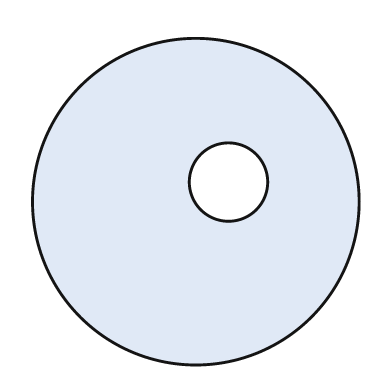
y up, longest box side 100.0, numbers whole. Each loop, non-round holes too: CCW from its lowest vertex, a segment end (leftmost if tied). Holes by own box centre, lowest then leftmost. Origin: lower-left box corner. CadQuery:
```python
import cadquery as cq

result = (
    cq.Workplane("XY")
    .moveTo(50.0, 50.0)
    .circle(50.0)
    .moveTo(60.0, 56.0)
    .circle(12.0)
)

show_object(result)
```